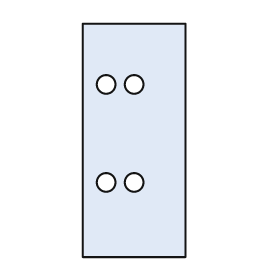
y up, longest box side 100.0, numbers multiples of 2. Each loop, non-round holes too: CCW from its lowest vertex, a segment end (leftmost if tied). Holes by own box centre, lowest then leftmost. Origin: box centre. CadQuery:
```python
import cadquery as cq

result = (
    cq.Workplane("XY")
    .moveTo(-22.0, -50.0)
    .lineTo(22.0, -50.0)
    .lineTo(22.0, 50.0)
    .lineTo(-22.0, 50.0)
    .close()
    .moveTo(-12.0, -18.0)
    .circle(4.0)
    .moveTo(0.0, -18.0)
    .circle(4.0)
    .moveTo(-12.0, 24.0)
    .circle(4.0)
    .moveTo(0.0, 24.0)
    .circle(4.0)
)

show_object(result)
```